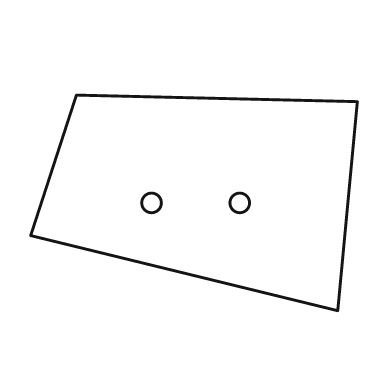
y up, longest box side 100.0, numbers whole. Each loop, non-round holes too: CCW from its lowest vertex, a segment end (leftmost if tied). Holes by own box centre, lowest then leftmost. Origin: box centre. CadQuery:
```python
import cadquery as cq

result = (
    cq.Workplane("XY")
    .moveTo(44.0, -33.0)
    .lineTo(50.0, 31.0)
    .lineTo(-36.0, 33.0)
    .lineTo(-50.0, -10.0)
    .close()
    .moveTo(-13.0, 0.0)
    .circle(3.0)
    .moveTo(14.0, 0.0)
    .circle(3.0)
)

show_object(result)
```